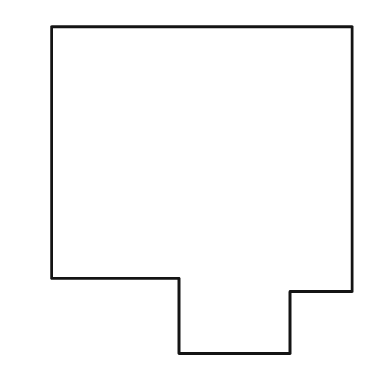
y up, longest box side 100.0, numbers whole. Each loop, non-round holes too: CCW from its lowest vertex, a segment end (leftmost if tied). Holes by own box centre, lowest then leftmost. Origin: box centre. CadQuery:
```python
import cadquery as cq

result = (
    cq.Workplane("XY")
    .moveTo(-7.0, -50.0)
    .lineTo(27.0, -50.0)
    .lineTo(27.0, -31.0)
    .lineTo(46.0, -31.0)
    .lineTo(46.0, 50.0)
    .lineTo(-46.0, 50.0)
    .lineTo(-46.0, -27.0)
    .lineTo(-7.0, -27.0)
    .close()
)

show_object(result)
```